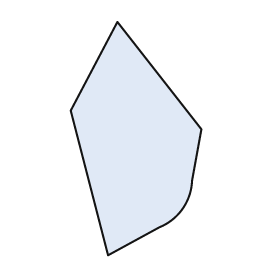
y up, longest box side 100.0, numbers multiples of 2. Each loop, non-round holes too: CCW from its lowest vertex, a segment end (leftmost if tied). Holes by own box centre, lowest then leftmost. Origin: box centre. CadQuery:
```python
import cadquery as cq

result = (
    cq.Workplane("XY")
    .moveTo(-12.0, -50.0)
    .lineTo(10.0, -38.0)
    .threePointArc((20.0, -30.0), (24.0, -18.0))
    .lineTo(28.0, 4.0)
    .lineTo(-8.0, 50.0)
    .lineTo(-28.0, 12.0)
    .close()
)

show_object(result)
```